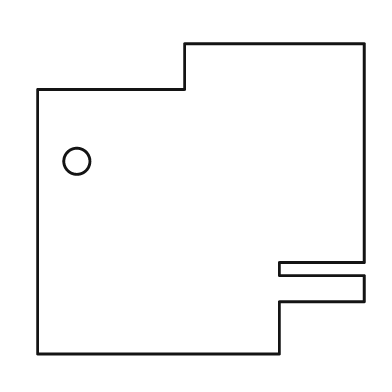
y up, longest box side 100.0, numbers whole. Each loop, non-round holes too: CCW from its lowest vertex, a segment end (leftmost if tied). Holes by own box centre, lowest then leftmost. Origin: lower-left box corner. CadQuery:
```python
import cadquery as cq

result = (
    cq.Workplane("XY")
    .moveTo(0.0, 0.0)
    .lineTo(74.0, 0.0)
    .lineTo(74.0, 16.0)
    .lineTo(100.0, 16.0)
    .lineTo(100.0, 24.0)
    .lineTo(74.0, 24.0)
    .lineTo(74.0, 28.0)
    .lineTo(100.0, 28.0)
    .lineTo(100.0, 95.0)
    .lineTo(45.0, 95.0)
    .lineTo(45.0, 81.0)
    .lineTo(0.0, 81.0)
    .close()
    .moveTo(12.0, 59.0)
    .circle(4.0)
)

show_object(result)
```